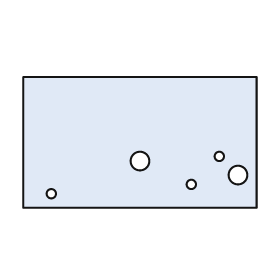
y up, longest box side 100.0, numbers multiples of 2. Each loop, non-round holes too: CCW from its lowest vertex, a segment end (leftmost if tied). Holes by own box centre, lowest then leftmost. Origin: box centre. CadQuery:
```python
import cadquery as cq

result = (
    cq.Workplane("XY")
    .moveTo(-50.0, -28.0)
    .lineTo(50.0, -28.0)
    .lineTo(50.0, 28.0)
    .lineTo(-50.0, 28.0)
    .close()
    .moveTo(-38.0, -22.0)
    .circle(2.0)
    .moveTo(22.0, -18.0)
    .circle(2.0)
    .moveTo(42.0, -14.0)
    .circle(4.0)
    .moveTo(0.0, -8.0)
    .circle(4.0)
    .moveTo(34.0, -6.0)
    .circle(2.0)
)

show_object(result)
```